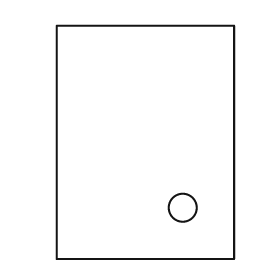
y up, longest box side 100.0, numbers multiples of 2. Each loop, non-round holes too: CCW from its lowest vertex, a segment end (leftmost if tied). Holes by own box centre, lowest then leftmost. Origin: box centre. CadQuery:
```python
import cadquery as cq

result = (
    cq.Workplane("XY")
    .moveTo(-38.0, -50.0)
    .lineTo(38.0, -50.0)
    .lineTo(38.0, 50.0)
    .lineTo(-38.0, 50.0)
    .close()
    .moveTo(16.0, -28.0)
    .circle(6.0)
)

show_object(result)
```